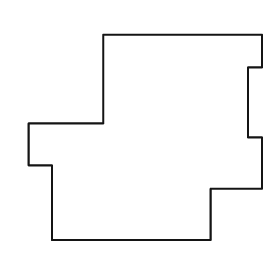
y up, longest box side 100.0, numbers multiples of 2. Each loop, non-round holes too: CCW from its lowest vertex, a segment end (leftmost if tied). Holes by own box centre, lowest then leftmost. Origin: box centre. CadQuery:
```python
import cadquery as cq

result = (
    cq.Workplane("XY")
    .moveTo(-40.0, -44.0)
    .lineTo(28.0, -44.0)
    .lineTo(28.0, -22.0)
    .lineTo(50.0, -22.0)
    .lineTo(50.0, 0.0)
    .lineTo(44.0, 0.0)
    .lineTo(44.0, 30.0)
    .lineTo(50.0, 30.0)
    .lineTo(50.0, 44.0)
    .lineTo(-18.0, 44.0)
    .lineTo(-18.0, 6.0)
    .lineTo(-50.0, 6.0)
    .lineTo(-50.0, -12.0)
    .lineTo(-40.0, -12.0)
    .close()
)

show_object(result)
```